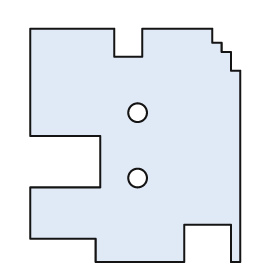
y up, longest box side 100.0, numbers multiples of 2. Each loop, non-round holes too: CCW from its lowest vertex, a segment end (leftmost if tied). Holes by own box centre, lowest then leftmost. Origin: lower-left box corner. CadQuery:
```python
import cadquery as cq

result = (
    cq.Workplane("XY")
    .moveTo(28.0, 0.0)
    .lineTo(66.0, 0.0)
    .lineTo(66.0, 16.0)
    .lineTo(86.0, 16.0)
    .lineTo(86.0, 0.0)
    .lineTo(90.0, 0.0)
    .lineTo(90.0, 82.0)
    .lineTo(86.0, 82.0)
    .lineTo(86.0, 90.0)
    .lineTo(82.0, 90.0)
    .lineTo(82.0, 94.0)
    .lineTo(78.0, 94.0)
    .lineTo(78.0, 100.0)
    .lineTo(48.0, 100.0)
    .lineTo(48.0, 88.0)
    .lineTo(36.0, 88.0)
    .lineTo(36.0, 100.0)
    .lineTo(0.0, 100.0)
    .lineTo(0.0, 54.0)
    .lineTo(30.0, 54.0)
    .lineTo(30.0, 32.0)
    .lineTo(0.0, 32.0)
    .lineTo(0.0, 10.0)
    .lineTo(28.0, 10.0)
    .close()
    .moveTo(46.0, 36.0)
    .circle(4.0)
    .moveTo(46.0, 64.0)
    .circle(4.0)
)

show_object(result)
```